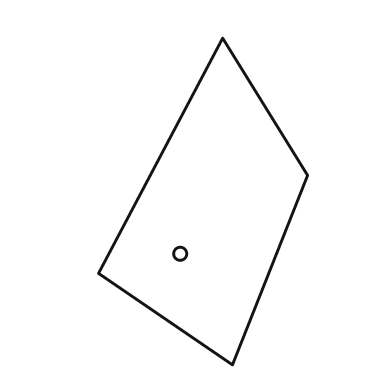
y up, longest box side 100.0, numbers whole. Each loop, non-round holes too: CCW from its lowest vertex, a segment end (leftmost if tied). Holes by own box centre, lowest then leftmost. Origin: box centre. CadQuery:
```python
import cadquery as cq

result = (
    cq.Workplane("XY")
    .moveTo(9.0, -50.0)
    .lineTo(32.0, 8.0)
    .lineTo(6.0, 50.0)
    .lineTo(-32.0, -22.0)
    .close()
    .moveTo(-7.0, -16.0)
    .circle(2.0)
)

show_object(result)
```